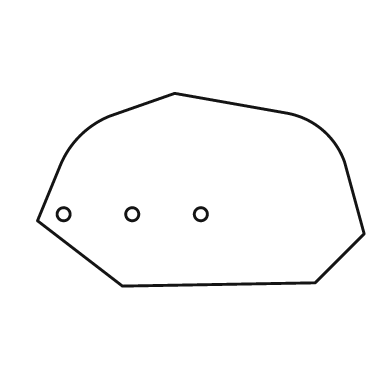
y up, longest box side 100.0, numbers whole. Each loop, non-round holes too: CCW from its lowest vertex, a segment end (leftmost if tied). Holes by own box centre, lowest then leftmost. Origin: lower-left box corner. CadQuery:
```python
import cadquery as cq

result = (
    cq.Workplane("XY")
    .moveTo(26.0, 0.0)
    .lineTo(85.0, 1.0)
    .lineTo(100.0, 16.0)
    .lineTo(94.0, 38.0)
    .threePointArc((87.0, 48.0), (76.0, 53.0))
    .lineTo(42.0, 59.0)
    .lineTo(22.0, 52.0)
    .threePointArc((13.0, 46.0), (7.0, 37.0))
    .lineTo(0.0, 20.0)
    .close()
    .moveTo(8.0, 22.0)
    .circle(2.0)
    .moveTo(29.0, 22.0)
    .circle(2.0)
    .moveTo(50.0, 22.0)
    .circle(2.0)
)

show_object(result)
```